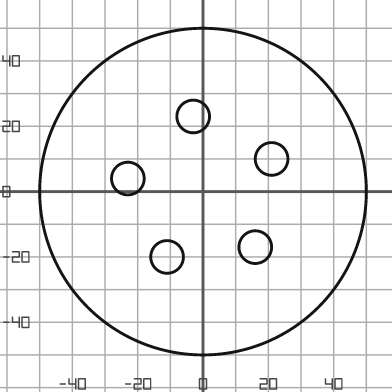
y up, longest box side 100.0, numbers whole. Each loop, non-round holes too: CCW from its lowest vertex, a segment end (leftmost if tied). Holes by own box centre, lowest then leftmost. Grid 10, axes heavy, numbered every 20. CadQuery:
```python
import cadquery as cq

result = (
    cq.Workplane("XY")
    .moveTo(0.0, 0.0)
    .circle(50.0)
    .moveTo(-11.0, -20.0)
    .circle(5.0)
    .moveTo(16.0, -17.0)
    .circle(5.0)
    .moveTo(-23.0, 4.0)
    .circle(5.0)
    .moveTo(21.0, 10.0)
    .circle(5.0)
    .moveTo(-3.0, 23.0)
    .circle(5.0)
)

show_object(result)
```